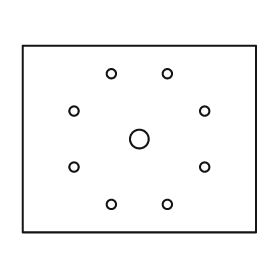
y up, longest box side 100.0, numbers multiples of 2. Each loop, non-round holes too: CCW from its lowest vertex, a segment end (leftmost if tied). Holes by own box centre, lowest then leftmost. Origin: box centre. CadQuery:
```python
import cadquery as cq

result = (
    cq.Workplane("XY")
    .moveTo(-50.0, -40.0)
    .lineTo(50.0, -40.0)
    .lineTo(50.0, 40.0)
    .lineTo(-50.0, 40.0)
    .close()
    .moveTo(-12.0, -28.0)
    .circle(2.0)
    .moveTo(12.0, -28.0)
    .circle(2.0)
    .moveTo(-28.0, -12.0)
    .circle(2.0)
    .moveTo(28.0, -12.0)
    .circle(2.0)
    .moveTo(0.0, 0.0)
    .circle(4.0)
    .moveTo(-28.0, 12.0)
    .circle(2.0)
    .moveTo(28.0, 12.0)
    .circle(2.0)
    .moveTo(-12.0, 28.0)
    .circle(2.0)
    .moveTo(12.0, 28.0)
    .circle(2.0)
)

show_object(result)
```